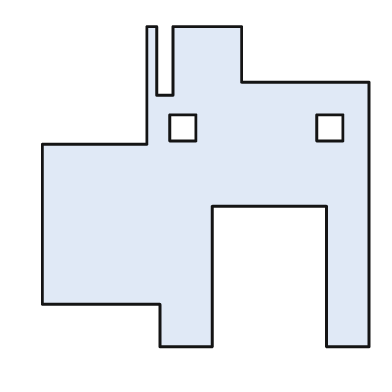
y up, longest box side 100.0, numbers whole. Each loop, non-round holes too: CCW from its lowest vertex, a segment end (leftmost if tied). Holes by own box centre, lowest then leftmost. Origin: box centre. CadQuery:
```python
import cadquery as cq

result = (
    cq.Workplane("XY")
    .moveTo(-14.0, -49.0)
    .lineTo(2.0, -49.0)
    .lineTo(2.0, -6.0)
    .lineTo(37.0, -6.0)
    .lineTo(37.0, -49.0)
    .lineTo(50.0, -49.0)
    .lineTo(50.0, 32.0)
    .lineTo(11.0, 32.0)
    .lineTo(11.0, 49.0)
    .lineTo(-10.0, 49.0)
    .lineTo(-10.0, 28.0)
    .lineTo(-15.0, 28.0)
    .lineTo(-15.0, 49.0)
    .lineTo(-18.0, 49.0)
    .lineTo(-18.0, 13.0)
    .lineTo(-50.0, 13.0)
    .lineTo(-50.0, -36.0)
    .lineTo(-14.0, -36.0)
    .close()
    .moveTo(-11.0, 14.0)
    .lineTo(-3.0, 14.0)
    .lineTo(-3.0, 22.0)
    .lineTo(-11.0, 22.0)
    .close()
    .moveTo(34.0, 14.0)
    .lineTo(42.0, 14.0)
    .lineTo(42.0, 22.0)
    .lineTo(34.0, 22.0)
    .close()
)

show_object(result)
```